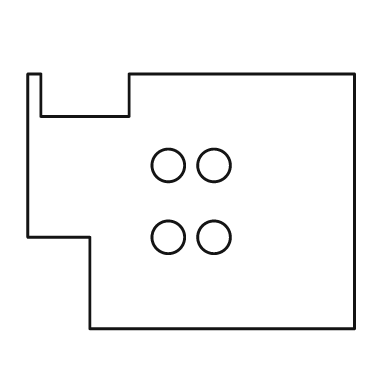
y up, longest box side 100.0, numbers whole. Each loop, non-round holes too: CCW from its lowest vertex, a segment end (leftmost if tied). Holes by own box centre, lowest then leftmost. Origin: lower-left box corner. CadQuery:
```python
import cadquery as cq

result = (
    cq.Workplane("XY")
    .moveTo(19.0, 0.0)
    .lineTo(100.0, 0.0)
    .lineTo(100.0, 78.0)
    .lineTo(31.0, 78.0)
    .lineTo(31.0, 65.0)
    .lineTo(4.0, 65.0)
    .lineTo(4.0, 78.0)
    .lineTo(0.0, 78.0)
    .lineTo(0.0, 28.0)
    .lineTo(19.0, 28.0)
    .close()
    .moveTo(43.0, 28.0)
    .circle(5.0)
    .moveTo(57.0, 28.0)
    .circle(5.0)
    .moveTo(43.0, 50.0)
    .circle(5.0)
    .moveTo(57.0, 50.0)
    .circle(5.0)
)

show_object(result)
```